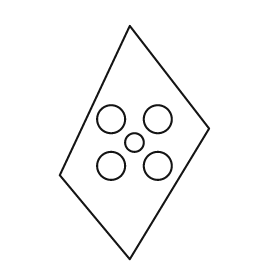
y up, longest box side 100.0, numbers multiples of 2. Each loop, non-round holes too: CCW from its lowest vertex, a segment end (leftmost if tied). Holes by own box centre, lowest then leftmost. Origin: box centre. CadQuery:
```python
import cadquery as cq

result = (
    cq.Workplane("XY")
    .moveTo(-2.0, -50.0)
    .lineTo(32.0, 6.0)
    .lineTo(-2.0, 50.0)
    .lineTo(-32.0, -14.0)
    .close()
    .moveTo(-10.0, -10.0)
    .circle(6.0)
    .moveTo(10.0, -10.0)
    .circle(6.0)
    .moveTo(0.0, 0.0)
    .circle(4.0)
    .moveTo(-10.0, 10.0)
    .circle(6.0)
    .moveTo(10.0, 10.0)
    .circle(6.0)
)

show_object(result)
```